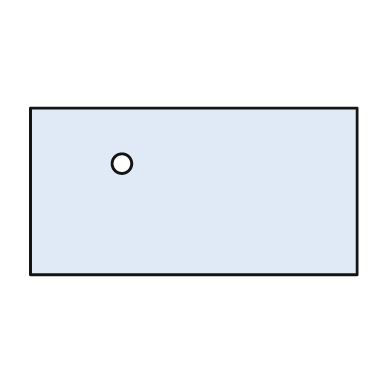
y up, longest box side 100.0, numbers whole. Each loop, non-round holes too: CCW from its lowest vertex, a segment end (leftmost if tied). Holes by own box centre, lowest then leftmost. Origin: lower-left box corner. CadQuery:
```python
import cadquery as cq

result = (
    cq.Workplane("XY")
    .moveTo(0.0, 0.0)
    .lineTo(100.0, 0.0)
    .lineTo(100.0, 51.0)
    .lineTo(0.0, 51.0)
    .close()
    .moveTo(28.0, 34.0)
    .circle(3.0)
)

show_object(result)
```